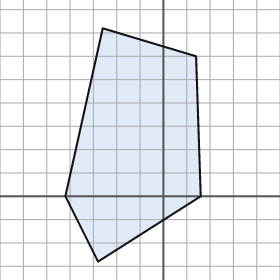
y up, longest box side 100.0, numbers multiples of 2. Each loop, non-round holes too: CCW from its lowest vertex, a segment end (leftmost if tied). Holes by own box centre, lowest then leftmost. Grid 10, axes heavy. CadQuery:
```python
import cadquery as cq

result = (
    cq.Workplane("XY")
    .moveTo(-28.0, -28.0)
    .lineTo(16.0, 0.0)
    .lineTo(14.0, 60.0)
    .lineTo(-26.0, 72.0)
    .lineTo(-42.0, 0.0)
    .close()
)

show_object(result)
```